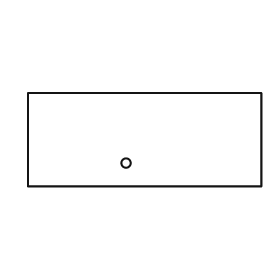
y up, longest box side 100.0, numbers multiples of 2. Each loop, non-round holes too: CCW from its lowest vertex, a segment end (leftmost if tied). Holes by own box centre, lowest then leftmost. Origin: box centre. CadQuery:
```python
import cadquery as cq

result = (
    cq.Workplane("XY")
    .moveTo(-50.0, -20.0)
    .lineTo(50.0, -20.0)
    .lineTo(50.0, 20.0)
    .lineTo(-50.0, 20.0)
    .close()
    .moveTo(-8.0, -10.0)
    .circle(2.0)
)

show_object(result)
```